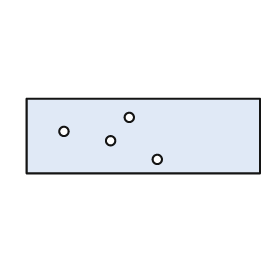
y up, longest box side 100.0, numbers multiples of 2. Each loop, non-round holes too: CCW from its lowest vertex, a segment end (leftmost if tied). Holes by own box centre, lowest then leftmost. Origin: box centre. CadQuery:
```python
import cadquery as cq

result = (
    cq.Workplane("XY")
    .moveTo(-50.0, -16.0)
    .lineTo(50.0, -16.0)
    .lineTo(50.0, 16.0)
    .lineTo(-50.0, 16.0)
    .close()
    .moveTo(6.0, -10.0)
    .circle(2.0)
    .moveTo(-14.0, -2.0)
    .circle(2.0)
    .moveTo(-34.0, 2.0)
    .circle(2.0)
    .moveTo(-6.0, 8.0)
    .circle(2.0)
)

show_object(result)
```